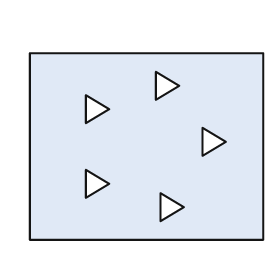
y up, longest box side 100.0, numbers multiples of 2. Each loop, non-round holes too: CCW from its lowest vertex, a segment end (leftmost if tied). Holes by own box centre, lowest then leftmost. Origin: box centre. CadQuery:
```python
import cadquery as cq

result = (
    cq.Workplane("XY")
    .moveTo(-50.0, -40.0)
    .lineTo(50.0, -40.0)
    .lineTo(50.0, 40.0)
    .lineTo(-50.0, 40.0)
    .close()
    .moveTo(6.0, -32.0)
    .lineTo(16.0, -26.0)
    .lineTo(6.0, -20.0)
    .close()
    .moveTo(-26.0, -22.0)
    .lineTo(-16.0, -16.0)
    .lineTo(-26.0, -10.0)
    .close()
    .moveTo(24.0, -4.0)
    .lineTo(34.0, 2.0)
    .lineTo(24.0, 8.0)
    .close()
    .moveTo(-26.0, 10.0)
    .lineTo(-16.0, 16.0)
    .lineTo(-26.0, 22.0)
    .close()
    .moveTo(4.0, 20.0)
    .lineTo(14.0, 26.0)
    .lineTo(4.0, 32.0)
    .close()
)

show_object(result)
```